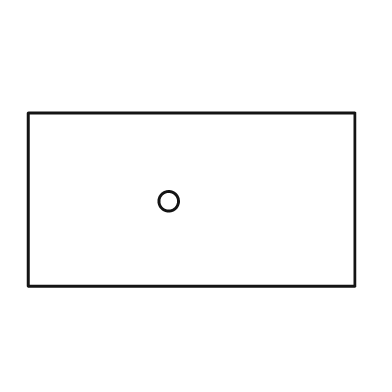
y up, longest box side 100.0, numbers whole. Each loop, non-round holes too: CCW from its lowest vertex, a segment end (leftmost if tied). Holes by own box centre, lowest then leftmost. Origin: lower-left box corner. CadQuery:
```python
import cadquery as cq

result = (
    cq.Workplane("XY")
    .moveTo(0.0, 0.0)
    .lineTo(100.0, 0.0)
    .lineTo(100.0, 53.0)
    .lineTo(0.0, 53.0)
    .close()
    .moveTo(43.0, 26.0)
    .circle(3.0)
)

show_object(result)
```